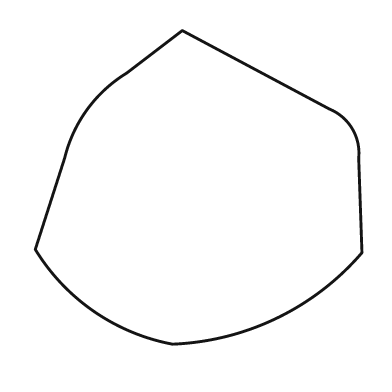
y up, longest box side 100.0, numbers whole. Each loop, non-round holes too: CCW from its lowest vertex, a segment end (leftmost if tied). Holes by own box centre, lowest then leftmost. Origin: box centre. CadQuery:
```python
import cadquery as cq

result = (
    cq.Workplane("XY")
    .moveTo(-8.0, -48.0)
    .threePointArc((24.0, -40.0), (50.0, -20.0))
    .lineTo(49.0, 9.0)
    .threePointArc((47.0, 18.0), (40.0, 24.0))
    .lineTo(-5.0, 48.0)
    .lineTo(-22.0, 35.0)
    .threePointArc((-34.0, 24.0), (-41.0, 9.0))
    .lineTo(-50.0, -19.0)
    .threePointArc((-32.0, -38.0), (-8.0, -48.0))
    .close()
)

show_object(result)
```